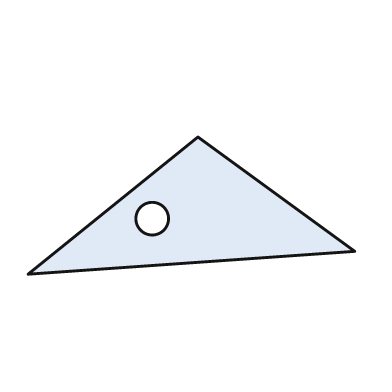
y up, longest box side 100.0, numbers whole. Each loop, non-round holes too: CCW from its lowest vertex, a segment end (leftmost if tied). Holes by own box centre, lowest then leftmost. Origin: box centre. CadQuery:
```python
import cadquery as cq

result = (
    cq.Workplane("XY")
    .moveTo(-50.0, -21.0)
    .lineTo(50.0, -14.0)
    .lineTo(2.0, 21.0)
    .close()
    .moveTo(-12.0, -4.0)
    .circle(5.0)
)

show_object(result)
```